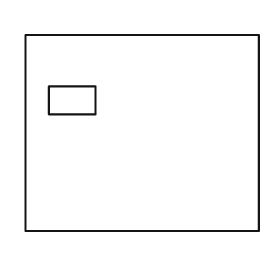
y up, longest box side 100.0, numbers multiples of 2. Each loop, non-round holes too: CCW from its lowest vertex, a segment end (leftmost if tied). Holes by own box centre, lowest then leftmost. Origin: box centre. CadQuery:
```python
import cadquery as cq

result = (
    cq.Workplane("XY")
    .moveTo(-50.0, -42.0)
    .lineTo(50.0, -42.0)
    .lineTo(50.0, 42.0)
    .lineTo(-50.0, 42.0)
    .close()
    .moveTo(-40.0, 8.0)
    .lineTo(-20.0, 8.0)
    .lineTo(-20.0, 20.0)
    .lineTo(-40.0, 20.0)
    .close()
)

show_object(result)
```